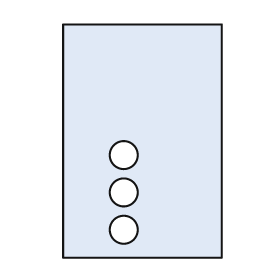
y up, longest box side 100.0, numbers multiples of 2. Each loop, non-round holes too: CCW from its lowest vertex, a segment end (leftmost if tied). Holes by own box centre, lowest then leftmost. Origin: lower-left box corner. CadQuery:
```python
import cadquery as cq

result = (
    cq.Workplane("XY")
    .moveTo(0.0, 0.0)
    .lineTo(68.0, 0.0)
    .lineTo(68.0, 100.0)
    .lineTo(0.0, 100.0)
    .close()
    .moveTo(26.0, 12.0)
    .circle(6.0)
    .moveTo(26.0, 28.0)
    .circle(6.0)
    .moveTo(26.0, 44.0)
    .circle(6.0)
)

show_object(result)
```